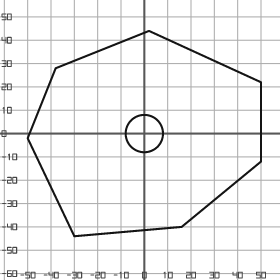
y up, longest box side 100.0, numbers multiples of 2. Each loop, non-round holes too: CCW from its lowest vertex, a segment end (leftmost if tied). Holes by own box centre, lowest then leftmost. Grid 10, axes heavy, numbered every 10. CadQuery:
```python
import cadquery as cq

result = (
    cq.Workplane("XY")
    .moveTo(-30.0, -44.0)
    .lineTo(16.0, -40.0)
    .lineTo(50.0, -12.0)
    .lineTo(50.0, 22.0)
    .lineTo(2.0, 44.0)
    .lineTo(-38.0, 28.0)
    .lineTo(-50.0, -2.0)
    .close()
    .moveTo(0.0, 0.0)
    .circle(8.0)
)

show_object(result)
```